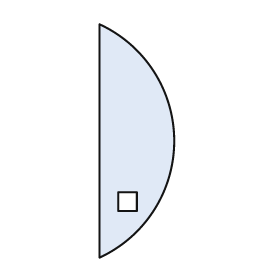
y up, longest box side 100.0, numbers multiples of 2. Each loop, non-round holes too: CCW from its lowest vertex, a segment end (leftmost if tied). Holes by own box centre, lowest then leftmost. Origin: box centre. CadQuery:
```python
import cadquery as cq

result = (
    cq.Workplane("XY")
    .moveTo(-16.0, -50.0)
    .threePointArc((16.0, 0.0), (-16.0, 50.0))
    .close()
    .moveTo(-8.0, -30.0)
    .lineTo(0.0, -30.0)
    .lineTo(0.0, -22.0)
    .lineTo(-8.0, -22.0)
    .close()
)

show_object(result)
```